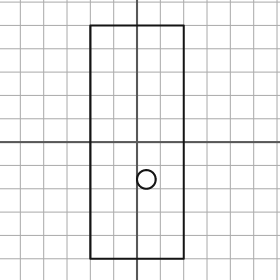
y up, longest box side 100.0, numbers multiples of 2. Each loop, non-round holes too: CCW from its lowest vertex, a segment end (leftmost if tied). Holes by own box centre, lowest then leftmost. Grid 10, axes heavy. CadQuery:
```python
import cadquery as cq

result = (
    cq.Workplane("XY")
    .moveTo(-20.0, -50.0)
    .lineTo(20.0, -50.0)
    .lineTo(20.0, 50.0)
    .lineTo(-20.0, 50.0)
    .close()
    .moveTo(4.0, -16.0)
    .circle(4.0)
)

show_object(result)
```